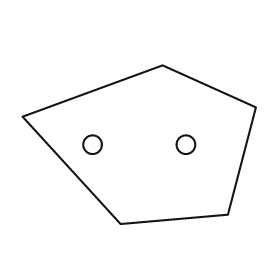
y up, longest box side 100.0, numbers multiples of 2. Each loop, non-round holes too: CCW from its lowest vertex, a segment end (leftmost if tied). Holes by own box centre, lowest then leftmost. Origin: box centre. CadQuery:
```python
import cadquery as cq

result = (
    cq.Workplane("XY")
    .moveTo(-8.0, -34.0)
    .lineTo(38.0, -30.0)
    .lineTo(50.0, 16.0)
    .lineTo(10.0, 34.0)
    .lineTo(-50.0, 12.0)
    .close()
    .moveTo(-20.0, 0.0)
    .circle(4.0)
    .moveTo(20.0, 0.0)
    .circle(4.0)
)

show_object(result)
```